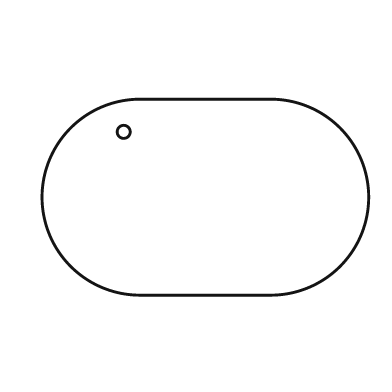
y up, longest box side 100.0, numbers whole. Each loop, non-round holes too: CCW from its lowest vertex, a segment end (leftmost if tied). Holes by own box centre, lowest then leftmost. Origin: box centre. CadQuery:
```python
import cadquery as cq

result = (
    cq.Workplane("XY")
    .moveTo(-20.0, -30.0)
    .lineTo(20.0, -30.0)
    .threePointArc((50.0, 0.0), (20.0, 30.0))
    .lineTo(-20.0, 30.0)
    .threePointArc((-50.0, 0.0), (-20.0, -30.0))
    .close()
    .moveTo(-25.0, 20.0)
    .circle(2.0)
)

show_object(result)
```